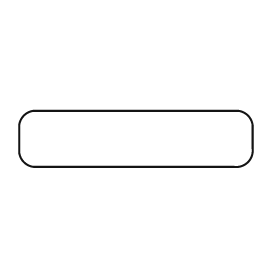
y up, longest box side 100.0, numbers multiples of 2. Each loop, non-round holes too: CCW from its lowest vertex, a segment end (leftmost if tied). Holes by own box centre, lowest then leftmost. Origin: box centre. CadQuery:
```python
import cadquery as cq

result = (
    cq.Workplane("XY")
    .moveTo(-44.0, -12.0)
    .lineTo(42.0, -12.0)
    .threePointArc((48.0, -10.0), (50.0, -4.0))
    .lineTo(50.0, 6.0)
    .threePointArc((48.0, 10.0), (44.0, 12.0))
    .lineTo(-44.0, 12.0)
    .threePointArc((-48.0, 10.0), (-50.0, 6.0))
    .lineTo(-50.0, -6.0)
    .threePointArc((-48.0, -10.0), (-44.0, -12.0))
    .close()
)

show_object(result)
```